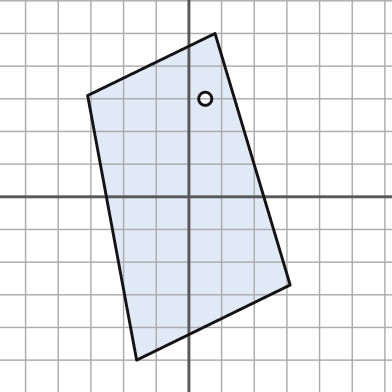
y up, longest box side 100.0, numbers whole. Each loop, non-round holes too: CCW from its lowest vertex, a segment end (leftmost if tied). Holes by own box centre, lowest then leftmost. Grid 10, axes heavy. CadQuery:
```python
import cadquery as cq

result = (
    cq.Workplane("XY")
    .moveTo(-16.0, -50.0)
    .lineTo(31.0, -27.0)
    .lineTo(8.0, 50.0)
    .lineTo(-31.0, 31.0)
    .close()
    .moveTo(5.0, 30.0)
    .circle(2.0)
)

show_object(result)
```